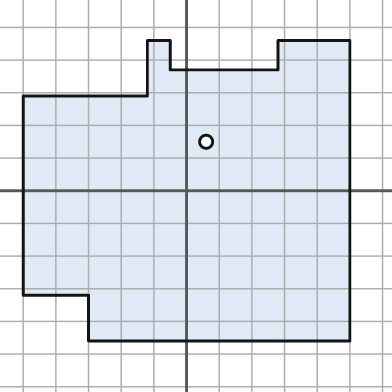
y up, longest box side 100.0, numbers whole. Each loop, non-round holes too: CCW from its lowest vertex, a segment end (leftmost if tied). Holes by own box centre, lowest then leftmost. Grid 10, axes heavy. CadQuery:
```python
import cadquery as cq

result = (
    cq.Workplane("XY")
    .moveTo(-30.0, -46.0)
    .lineTo(50.0, -46.0)
    .lineTo(50.0, 46.0)
    .lineTo(28.0, 46.0)
    .lineTo(28.0, 37.0)
    .lineTo(-5.0, 37.0)
    .lineTo(-5.0, 46.0)
    .lineTo(-12.0, 46.0)
    .lineTo(-12.0, 29.0)
    .lineTo(-50.0, 29.0)
    .lineTo(-50.0, -32.0)
    .lineTo(-30.0, -32.0)
    .close()
    .moveTo(6.0, 15.0)
    .circle(2.0)
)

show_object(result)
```